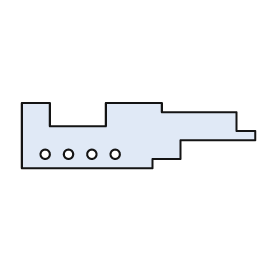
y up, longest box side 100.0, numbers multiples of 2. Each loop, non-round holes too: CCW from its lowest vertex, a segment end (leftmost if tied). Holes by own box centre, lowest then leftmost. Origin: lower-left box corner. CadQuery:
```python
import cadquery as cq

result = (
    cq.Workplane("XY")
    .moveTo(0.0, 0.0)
    .lineTo(56.0, 0.0)
    .lineTo(56.0, 4.0)
    .lineTo(68.0, 4.0)
    .lineTo(68.0, 12.0)
    .lineTo(100.0, 12.0)
    .lineTo(100.0, 16.0)
    .lineTo(92.0, 16.0)
    .lineTo(92.0, 24.0)
    .lineTo(60.0, 24.0)
    .lineTo(60.0, 28.0)
    .lineTo(36.0, 28.0)
    .lineTo(36.0, 18.0)
    .lineTo(12.0, 18.0)
    .lineTo(12.0, 28.0)
    .lineTo(0.0, 28.0)
    .close()
    .moveTo(10.0, 6.0)
    .circle(2.0)
    .moveTo(20.0, 6.0)
    .circle(2.0)
    .moveTo(30.0, 6.0)
    .circle(2.0)
    .moveTo(40.0, 6.0)
    .circle(2.0)
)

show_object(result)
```